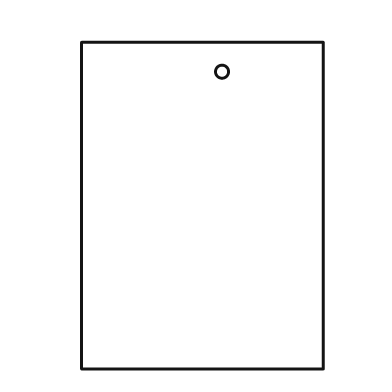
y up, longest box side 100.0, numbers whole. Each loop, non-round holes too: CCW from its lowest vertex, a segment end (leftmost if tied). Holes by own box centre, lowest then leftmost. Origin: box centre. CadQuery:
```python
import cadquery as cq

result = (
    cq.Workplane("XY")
    .moveTo(-37.0, -50.0)
    .lineTo(37.0, -50.0)
    .lineTo(37.0, 50.0)
    .lineTo(-37.0, 50.0)
    .close()
    .moveTo(6.0, 41.0)
    .circle(2.0)
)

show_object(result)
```